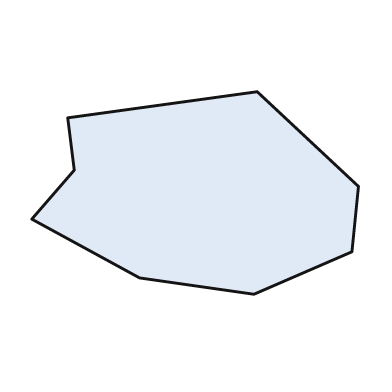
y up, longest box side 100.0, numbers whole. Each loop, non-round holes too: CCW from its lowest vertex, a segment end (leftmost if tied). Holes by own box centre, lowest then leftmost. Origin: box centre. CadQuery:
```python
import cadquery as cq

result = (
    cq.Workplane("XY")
    .moveTo(18.0, -31.0)
    .lineTo(48.0, -18.0)
    .lineTo(50.0, 2.0)
    .lineTo(19.0, 31.0)
    .lineTo(-39.0, 23.0)
    .lineTo(-37.0, 7.0)
    .lineTo(-50.0, -8.0)
    .lineTo(-17.0, -26.0)
    .close()
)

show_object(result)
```